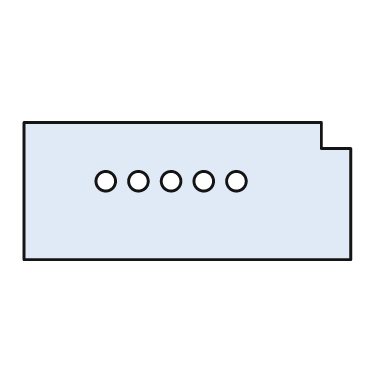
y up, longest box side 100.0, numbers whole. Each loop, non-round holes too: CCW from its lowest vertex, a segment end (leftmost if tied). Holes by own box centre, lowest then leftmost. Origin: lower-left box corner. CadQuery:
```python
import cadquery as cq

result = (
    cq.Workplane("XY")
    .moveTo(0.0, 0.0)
    .lineTo(100.0, 0.0)
    .lineTo(100.0, 34.0)
    .lineTo(91.0, 34.0)
    .lineTo(91.0, 42.0)
    .lineTo(0.0, 42.0)
    .close()
    .moveTo(25.0, 24.0)
    .circle(3.0)
    .moveTo(35.0, 24.0)
    .circle(3.0)
    .moveTo(45.0, 24.0)
    .circle(3.0)
    .moveTo(55.0, 24.0)
    .circle(3.0)
    .moveTo(65.0, 24.0)
    .circle(3.0)
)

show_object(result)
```